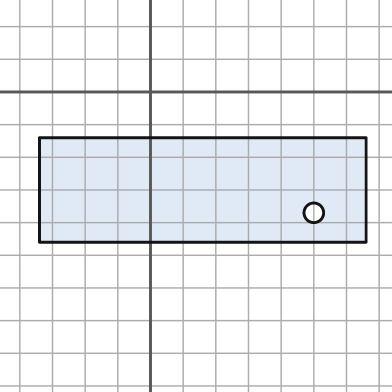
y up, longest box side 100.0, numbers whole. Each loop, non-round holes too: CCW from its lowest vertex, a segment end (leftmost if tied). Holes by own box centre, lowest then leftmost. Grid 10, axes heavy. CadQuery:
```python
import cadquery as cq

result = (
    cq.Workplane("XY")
    .moveTo(-34.0, -46.0)
    .lineTo(66.0, -46.0)
    .lineTo(66.0, -14.0)
    .lineTo(-34.0, -14.0)
    .close()
    .moveTo(50.0, -37.0)
    .circle(3.0)
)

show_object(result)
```